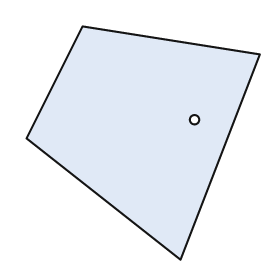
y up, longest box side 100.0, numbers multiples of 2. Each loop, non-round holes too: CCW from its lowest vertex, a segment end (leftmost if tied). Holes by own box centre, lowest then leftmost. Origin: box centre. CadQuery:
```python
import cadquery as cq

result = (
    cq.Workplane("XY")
    .moveTo(16.0, -50.0)
    .lineTo(50.0, 38.0)
    .lineTo(-26.0, 50.0)
    .lineTo(-50.0, 2.0)
    .close()
    .moveTo(22.0, 10.0)
    .circle(2.0)
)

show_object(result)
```